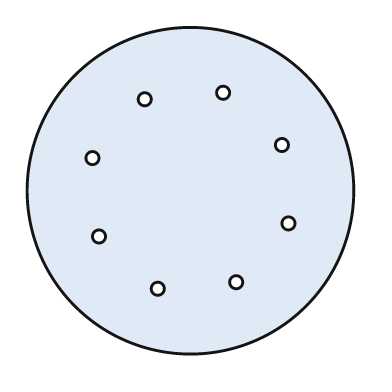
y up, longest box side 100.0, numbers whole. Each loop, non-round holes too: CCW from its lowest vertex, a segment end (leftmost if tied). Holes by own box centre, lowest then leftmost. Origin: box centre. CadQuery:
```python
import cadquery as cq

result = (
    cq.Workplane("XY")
    .moveTo(0.0, 0.0)
    .circle(50.0)
    .moveTo(-10.0, -30.0)
    .circle(2.0)
    .moveTo(14.0, -28.0)
    .circle(2.0)
    .moveTo(-28.0, -14.0)
    .circle(2.0)
    .moveTo(30.0, -10.0)
    .circle(2.0)
    .moveTo(-30.0, 10.0)
    .circle(2.0)
    .moveTo(28.0, 14.0)
    .circle(2.0)
    .moveTo(-14.0, 28.0)
    .circle(2.0)
    .moveTo(10.0, 30.0)
    .circle(2.0)
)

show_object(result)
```